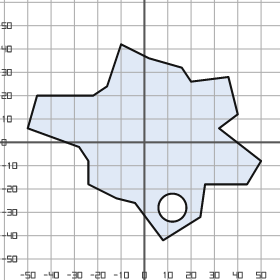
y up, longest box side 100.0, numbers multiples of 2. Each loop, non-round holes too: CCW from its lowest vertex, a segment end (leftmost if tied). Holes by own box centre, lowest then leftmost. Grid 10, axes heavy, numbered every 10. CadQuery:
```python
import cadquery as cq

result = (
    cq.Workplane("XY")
    .moveTo(8.0, -42.0)
    .lineTo(24.0, -32.0)
    .lineTo(26.0, -18.0)
    .lineTo(44.0, -18.0)
    .lineTo(50.0, -8.0)
    .lineTo(32.0, 6.0)
    .lineTo(40.0, 12.0)
    .lineTo(36.0, 28.0)
    .lineTo(20.0, 26.0)
    .lineTo(16.0, 32.0)
    .lineTo(2.0, 36.0)
    .lineTo(-10.0, 42.0)
    .lineTo(-16.0, 24.0)
    .lineTo(-22.0, 20.0)
    .lineTo(-46.0, 20.0)
    .lineTo(-50.0, 6.0)
    .lineTo(-28.0, -2.0)
    .lineTo(-24.0, -8.0)
    .lineTo(-24.0, -18.0)
    .lineTo(-12.0, -24.0)
    .lineTo(-4.0, -26.0)
    .close()
    .moveTo(12.0, -28.0)
    .circle(6.0)
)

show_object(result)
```